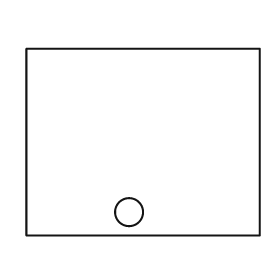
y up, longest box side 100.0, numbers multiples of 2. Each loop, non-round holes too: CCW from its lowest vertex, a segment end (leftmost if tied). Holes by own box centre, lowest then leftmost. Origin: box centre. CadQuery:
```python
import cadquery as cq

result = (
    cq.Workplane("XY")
    .moveTo(-50.0, -40.0)
    .lineTo(50.0, -40.0)
    .lineTo(50.0, 40.0)
    .lineTo(-50.0, 40.0)
    .close()
    .moveTo(-6.0, -30.0)
    .circle(6.0)
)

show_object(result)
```